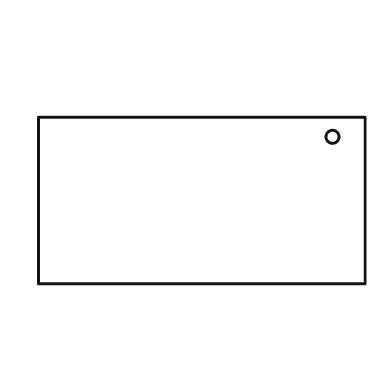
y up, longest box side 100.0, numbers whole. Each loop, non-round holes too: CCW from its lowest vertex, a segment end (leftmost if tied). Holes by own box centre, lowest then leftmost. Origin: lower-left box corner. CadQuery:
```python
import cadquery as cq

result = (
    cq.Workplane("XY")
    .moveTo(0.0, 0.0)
    .lineTo(100.0, 0.0)
    .lineTo(100.0, 51.0)
    .lineTo(0.0, 51.0)
    .close()
    .moveTo(90.0, 45.0)
    .circle(2.0)
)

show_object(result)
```